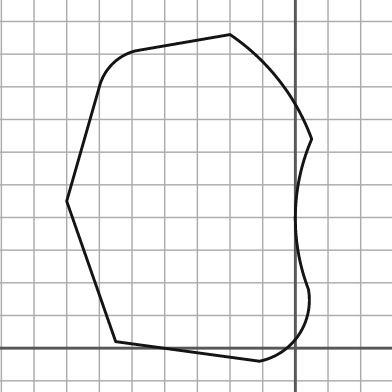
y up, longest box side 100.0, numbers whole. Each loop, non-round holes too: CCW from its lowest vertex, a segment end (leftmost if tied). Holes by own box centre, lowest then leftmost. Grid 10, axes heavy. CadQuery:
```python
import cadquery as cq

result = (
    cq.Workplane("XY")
    .moveTo(-11.0, -4.0)
    .threePointArc((1.0, 4.0), (4.0, 18.0))
    .threePointArc((0.0, 41.0), (5.0, 64.0))
    .threePointArc((-5.0, 82.0), (-20.0, 96.0))
    .lineTo(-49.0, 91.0)
    .threePointArc((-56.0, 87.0), (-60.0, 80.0))
    .lineTo(-70.0, 45.0)
    .lineTo(-55.0, 2.0)
    .close()
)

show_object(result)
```